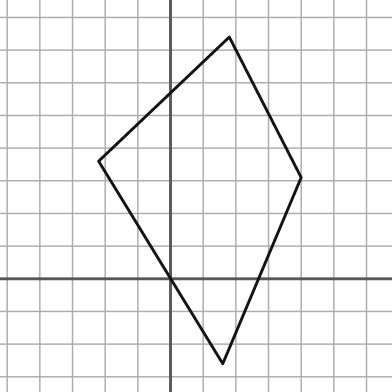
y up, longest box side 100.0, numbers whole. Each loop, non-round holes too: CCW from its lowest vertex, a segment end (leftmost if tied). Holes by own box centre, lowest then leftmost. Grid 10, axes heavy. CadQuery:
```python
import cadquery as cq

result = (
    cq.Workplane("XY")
    .moveTo(16.0, -26.0)
    .lineTo(40.0, 31.0)
    .lineTo(18.0, 74.0)
    .lineTo(-22.0, 36.0)
    .close()
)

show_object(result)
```